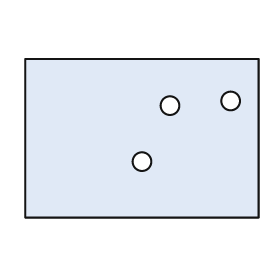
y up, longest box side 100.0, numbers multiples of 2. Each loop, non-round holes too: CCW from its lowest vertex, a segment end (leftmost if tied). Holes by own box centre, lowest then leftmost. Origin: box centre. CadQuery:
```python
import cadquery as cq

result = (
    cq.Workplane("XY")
    .moveTo(-50.0, -34.0)
    .lineTo(50.0, -34.0)
    .lineTo(50.0, 34.0)
    .lineTo(-50.0, 34.0)
    .close()
    .moveTo(0.0, -10.0)
    .circle(4.0)
    .moveTo(12.0, 14.0)
    .circle(4.0)
    .moveTo(38.0, 16.0)
    .circle(4.0)
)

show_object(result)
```